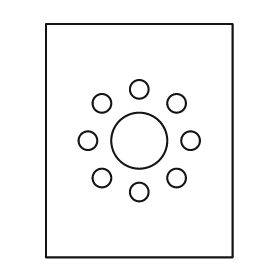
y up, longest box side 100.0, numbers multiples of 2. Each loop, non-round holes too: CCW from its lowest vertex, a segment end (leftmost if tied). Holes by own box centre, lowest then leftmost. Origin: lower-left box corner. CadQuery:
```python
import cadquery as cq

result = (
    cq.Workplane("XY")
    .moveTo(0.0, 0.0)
    .lineTo(80.0, 0.0)
    .lineTo(80.0, 100.0)
    .lineTo(0.0, 100.0)
    .close()
    .moveTo(40.0, 28.0)
    .circle(4.0)
    .moveTo(24.0, 34.0)
    .circle(4.0)
    .moveTo(56.0, 34.0)
    .circle(4.0)
    .moveTo(18.0, 50.0)
    .circle(4.0)
    .moveTo(40.0, 50.0)
    .circle(12.0)
    .moveTo(62.0, 50.0)
    .circle(4.0)
    .moveTo(24.0, 66.0)
    .circle(4.0)
    .moveTo(56.0, 66.0)
    .circle(4.0)
    .moveTo(40.0, 72.0)
    .circle(4.0)
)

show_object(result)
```